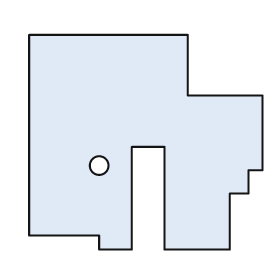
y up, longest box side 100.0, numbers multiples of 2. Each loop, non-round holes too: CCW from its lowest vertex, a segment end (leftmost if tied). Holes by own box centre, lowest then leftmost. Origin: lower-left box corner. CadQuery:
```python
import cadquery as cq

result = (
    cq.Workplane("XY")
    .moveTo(30.0, 0.0)
    .lineTo(44.0, 0.0)
    .lineTo(44.0, 44.0)
    .lineTo(58.0, 44.0)
    .lineTo(58.0, 0.0)
    .lineTo(86.0, 0.0)
    .lineTo(86.0, 24.0)
    .lineTo(94.0, 24.0)
    .lineTo(94.0, 34.0)
    .lineTo(100.0, 34.0)
    .lineTo(100.0, 66.0)
    .lineTo(68.0, 66.0)
    .lineTo(68.0, 92.0)
    .lineTo(0.0, 92.0)
    .lineTo(0.0, 6.0)
    .lineTo(30.0, 6.0)
    .close()
    .moveTo(30.0, 36.0)
    .circle(4.0)
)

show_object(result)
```